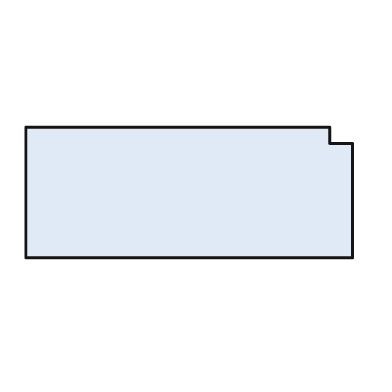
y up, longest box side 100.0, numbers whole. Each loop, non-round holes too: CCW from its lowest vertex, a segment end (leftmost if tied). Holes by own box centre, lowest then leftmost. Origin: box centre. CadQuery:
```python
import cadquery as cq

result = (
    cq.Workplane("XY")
    .moveTo(-50.0, -20.0)
    .lineTo(50.0, -20.0)
    .lineTo(50.0, 15.0)
    .lineTo(43.0, 15.0)
    .lineTo(43.0, 20.0)
    .lineTo(-50.0, 20.0)
    .close()
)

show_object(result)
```